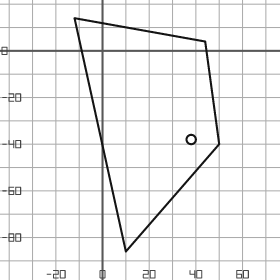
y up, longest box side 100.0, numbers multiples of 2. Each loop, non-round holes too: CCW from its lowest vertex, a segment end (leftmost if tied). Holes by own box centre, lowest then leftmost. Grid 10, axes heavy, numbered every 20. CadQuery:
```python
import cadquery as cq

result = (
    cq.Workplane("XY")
    .moveTo(10.0, -86.0)
    .lineTo(50.0, -40.0)
    .lineTo(44.0, 4.0)
    .lineTo(-12.0, 14.0)
    .close()
    .moveTo(38.0, -38.0)
    .circle(2.0)
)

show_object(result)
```